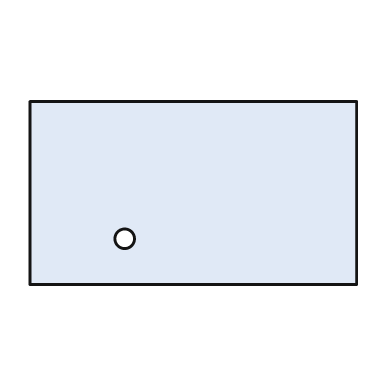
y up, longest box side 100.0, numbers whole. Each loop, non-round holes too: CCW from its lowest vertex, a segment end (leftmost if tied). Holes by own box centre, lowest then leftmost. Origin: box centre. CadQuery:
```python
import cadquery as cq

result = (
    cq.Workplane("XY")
    .moveTo(-50.0, -28.0)
    .lineTo(50.0, -28.0)
    .lineTo(50.0, 28.0)
    .lineTo(-50.0, 28.0)
    .close()
    .moveTo(-21.0, -14.0)
    .circle(3.0)
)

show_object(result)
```